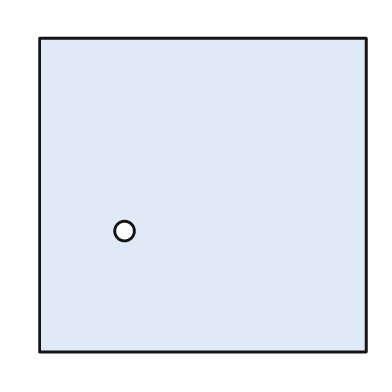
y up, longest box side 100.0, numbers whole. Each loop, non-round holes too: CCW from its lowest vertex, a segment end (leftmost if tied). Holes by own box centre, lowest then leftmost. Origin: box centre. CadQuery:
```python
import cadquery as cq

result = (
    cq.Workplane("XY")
    .moveTo(-50.0, -48.0)
    .lineTo(50.0, -48.0)
    .lineTo(50.0, 48.0)
    .lineTo(-50.0, 48.0)
    .close()
    .moveTo(-24.0, -11.0)
    .circle(3.0)
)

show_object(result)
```